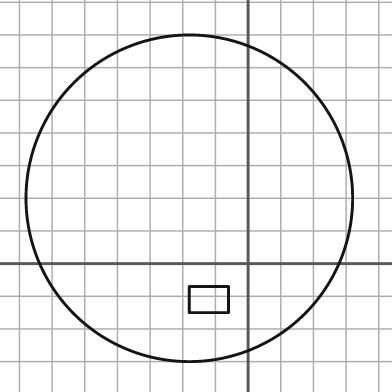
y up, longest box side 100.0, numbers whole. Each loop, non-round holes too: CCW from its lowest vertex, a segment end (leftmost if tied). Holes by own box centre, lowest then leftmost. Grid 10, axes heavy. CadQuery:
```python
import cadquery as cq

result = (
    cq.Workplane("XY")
    .moveTo(-18.0, 20.0)
    .circle(50.0)
    .moveTo(-18.0, -15.0)
    .lineTo(-6.0, -15.0)
    .lineTo(-6.0, -7.0)
    .lineTo(-18.0, -7.0)
    .close()
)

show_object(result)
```